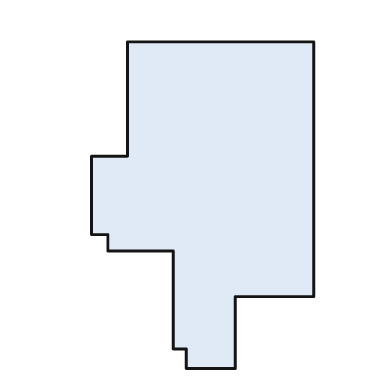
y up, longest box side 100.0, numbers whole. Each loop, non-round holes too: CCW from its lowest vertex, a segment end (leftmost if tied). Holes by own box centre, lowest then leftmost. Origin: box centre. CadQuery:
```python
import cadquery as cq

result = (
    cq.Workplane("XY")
    .moveTo(-5.0, -50.0)
    .lineTo(10.0, -50.0)
    .lineTo(10.0, -28.0)
    .lineTo(34.0, -28.0)
    .lineTo(34.0, 50.0)
    .lineTo(-23.0, 50.0)
    .lineTo(-23.0, 15.0)
    .lineTo(-34.0, 15.0)
    .lineTo(-34.0, -9.0)
    .lineTo(-29.0, -9.0)
    .lineTo(-29.0, -14.0)
    .lineTo(-9.0, -14.0)
    .lineTo(-9.0, -44.0)
    .lineTo(-5.0, -44.0)
    .close()
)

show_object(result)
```